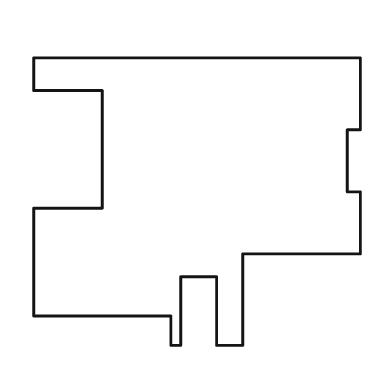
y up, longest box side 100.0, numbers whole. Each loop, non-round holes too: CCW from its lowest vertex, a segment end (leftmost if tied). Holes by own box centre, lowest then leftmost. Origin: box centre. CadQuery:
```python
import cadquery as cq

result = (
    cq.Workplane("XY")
    .moveTo(-8.0, -44.0)
    .lineTo(-5.0, -44.0)
    .lineTo(-5.0, -23.0)
    .lineTo(6.0, -23.0)
    .lineTo(6.0, -44.0)
    .lineTo(14.0, -44.0)
    .lineTo(14.0, -16.0)
    .lineTo(50.0, -16.0)
    .lineTo(50.0, 3.0)
    .lineTo(46.0, 3.0)
    .lineTo(46.0, 22.0)
    .lineTo(50.0, 22.0)
    .lineTo(50.0, 44.0)
    .lineTo(-50.0, 44.0)
    .lineTo(-50.0, 34.0)
    .lineTo(-29.0, 34.0)
    .lineTo(-29.0, -2.0)
    .lineTo(-50.0, -2.0)
    .lineTo(-50.0, -35.0)
    .lineTo(-8.0, -35.0)
    .close()
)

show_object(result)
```